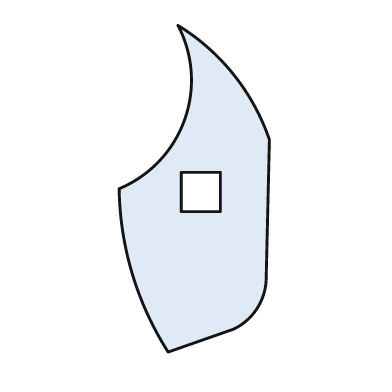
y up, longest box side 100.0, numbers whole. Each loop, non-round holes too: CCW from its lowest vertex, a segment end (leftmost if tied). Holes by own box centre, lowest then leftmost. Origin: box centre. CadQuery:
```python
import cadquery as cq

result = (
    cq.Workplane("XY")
    .moveTo(-8.0, -50.0)
    .lineTo(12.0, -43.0)
    .threePointArc((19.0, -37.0), (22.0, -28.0))
    .lineTo(23.0, 15.0)
    .threePointArc((12.0, 35.0), (-5.0, 50.0))
    .threePointArc((-3.0, 21.0), (-23.0, 0.0))
    .threePointArc((-19.0, -26.0), (-8.0, -50.0))
    .close()
    .moveTo(-4.0, -7.0)
    .lineTo(8.0, -7.0)
    .lineTo(8.0, 5.0)
    .lineTo(-4.0, 5.0)
    .close()
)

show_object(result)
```